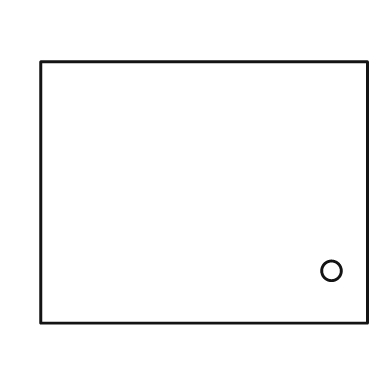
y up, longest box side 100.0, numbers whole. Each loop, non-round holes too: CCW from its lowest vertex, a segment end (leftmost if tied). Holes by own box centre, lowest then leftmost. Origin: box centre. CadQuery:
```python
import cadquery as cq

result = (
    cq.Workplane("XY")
    .moveTo(-50.0, -40.0)
    .lineTo(50.0, -40.0)
    .lineTo(50.0, 40.0)
    .lineTo(-50.0, 40.0)
    .close()
    .moveTo(39.0, -24.0)
    .circle(3.0)
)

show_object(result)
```